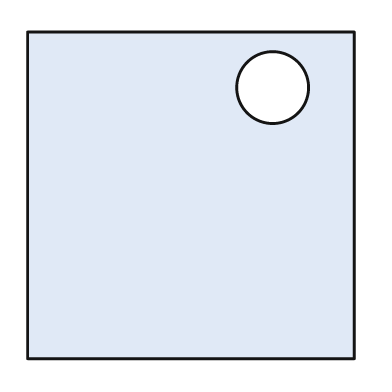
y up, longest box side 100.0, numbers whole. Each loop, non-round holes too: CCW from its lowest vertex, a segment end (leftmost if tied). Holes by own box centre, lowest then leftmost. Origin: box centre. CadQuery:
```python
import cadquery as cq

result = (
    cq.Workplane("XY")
    .moveTo(-50.0, -50.0)
    .lineTo(50.0, -50.0)
    .lineTo(50.0, 50.0)
    .lineTo(-50.0, 50.0)
    .close()
    .moveTo(25.0, 33.0)
    .circle(11.0)
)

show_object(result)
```